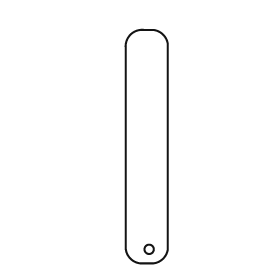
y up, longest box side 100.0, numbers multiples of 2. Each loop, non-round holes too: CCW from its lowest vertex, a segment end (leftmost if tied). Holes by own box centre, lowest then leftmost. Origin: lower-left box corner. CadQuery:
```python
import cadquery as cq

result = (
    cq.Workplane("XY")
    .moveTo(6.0, 0.0)
    .lineTo(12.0, 0.0)
    .threePointArc((16.0, 2.0), (18.0, 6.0))
    .lineTo(18.0, 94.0)
    .threePointArc((16.0, 98.0), (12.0, 100.0))
    .lineTo(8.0, 100.0)
    .threePointArc((2.0, 98.0), (0.0, 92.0))
    .lineTo(0.0, 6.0)
    .threePointArc((2.0, 2.0), (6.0, 0.0))
    .close()
    .moveTo(10.0, 6.0)
    .circle(2.0)
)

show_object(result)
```